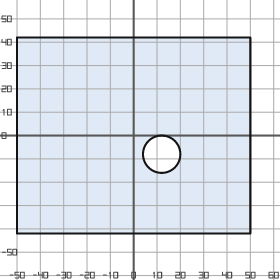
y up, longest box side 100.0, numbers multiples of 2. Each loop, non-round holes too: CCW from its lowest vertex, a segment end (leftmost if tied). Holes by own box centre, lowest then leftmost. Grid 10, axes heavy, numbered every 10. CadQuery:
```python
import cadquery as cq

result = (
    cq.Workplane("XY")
    .moveTo(-50.0, -42.0)
    .lineTo(50.0, -42.0)
    .lineTo(50.0, 42.0)
    .lineTo(-50.0, 42.0)
    .close()
    .moveTo(12.0, -8.0)
    .circle(8.0)
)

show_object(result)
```